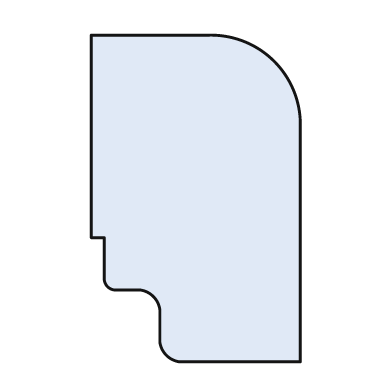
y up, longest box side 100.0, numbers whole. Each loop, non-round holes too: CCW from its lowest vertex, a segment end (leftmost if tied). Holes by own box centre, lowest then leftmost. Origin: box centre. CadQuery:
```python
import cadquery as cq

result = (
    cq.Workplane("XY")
    .moveTo(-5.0, -50.0)
    .lineTo(32.0, -50.0)
    .lineTo(32.0, 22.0)
    .threePointArc((24.0, 42.0), (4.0, 50.0))
    .lineTo(-32.0, 50.0)
    .lineTo(-32.0, -12.0)
    .lineTo(-28.0, -12.0)
    .lineTo(-28.0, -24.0)
    .threePointArc((-27.0, -27.0), (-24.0, -28.0))
    .lineTo(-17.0, -28.0)
    .threePointArc((-13.0, -30.0), (-11.0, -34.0))
    .lineTo(-11.0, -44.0)
    .threePointArc((-9.0, -48.0), (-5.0, -50.0))
    .close()
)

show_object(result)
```